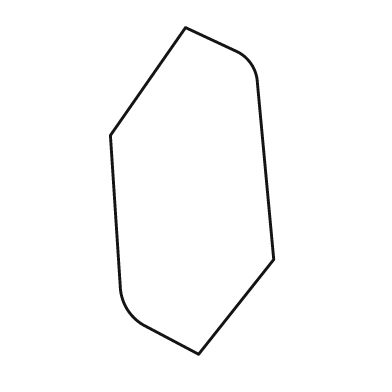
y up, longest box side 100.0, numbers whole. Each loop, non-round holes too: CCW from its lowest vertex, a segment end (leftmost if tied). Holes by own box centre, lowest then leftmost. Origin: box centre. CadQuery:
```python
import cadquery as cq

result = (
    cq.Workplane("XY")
    .moveTo(2.0, -50.0)
    .lineTo(25.0, -21.0)
    .lineTo(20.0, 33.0)
    .threePointArc((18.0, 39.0), (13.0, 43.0))
    .lineTo(-2.0, 50.0)
    .lineTo(-25.0, 17.0)
    .lineTo(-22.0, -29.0)
    .threePointArc((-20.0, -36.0), (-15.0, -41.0))
    .close()
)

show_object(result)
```